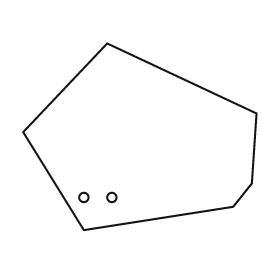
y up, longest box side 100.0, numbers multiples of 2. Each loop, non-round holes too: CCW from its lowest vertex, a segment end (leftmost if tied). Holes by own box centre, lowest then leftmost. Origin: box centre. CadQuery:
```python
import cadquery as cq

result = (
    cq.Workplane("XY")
    .moveTo(-24.0, -40.0)
    .lineTo(40.0, -30.0)
    .lineTo(48.0, -20.0)
    .lineTo(50.0, 10.0)
    .lineTo(-14.0, 40.0)
    .lineTo(-50.0, 2.0)
    .close()
    .moveTo(-24.0, -26.0)
    .circle(2.0)
    .moveTo(-12.0, -26.0)
    .circle(2.0)
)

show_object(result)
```